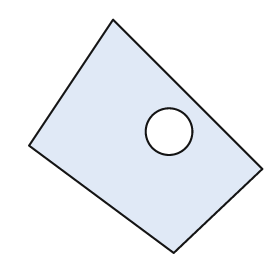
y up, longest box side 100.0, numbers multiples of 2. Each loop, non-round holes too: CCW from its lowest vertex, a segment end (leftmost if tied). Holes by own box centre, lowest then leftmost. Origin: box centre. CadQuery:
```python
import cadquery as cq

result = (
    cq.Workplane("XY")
    .moveTo(12.0, -50.0)
    .lineTo(50.0, -14.0)
    .lineTo(-14.0, 50.0)
    .lineTo(-50.0, -4.0)
    .close()
    .moveTo(10.0, 2.0)
    .circle(10.0)
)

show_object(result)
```